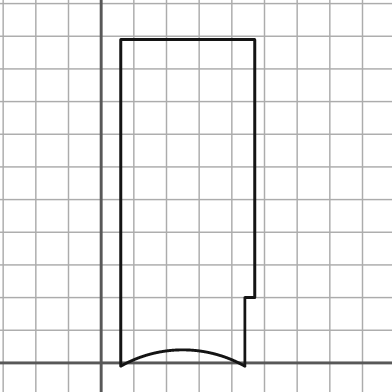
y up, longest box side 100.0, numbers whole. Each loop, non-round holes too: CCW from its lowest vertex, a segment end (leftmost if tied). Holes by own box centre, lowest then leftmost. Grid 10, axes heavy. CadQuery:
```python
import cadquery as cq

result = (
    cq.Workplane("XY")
    .moveTo(6.0, -1.0)
    .threePointArc((25.0, 4.0), (44.0, -1.0))
    .lineTo(44.0, 20.0)
    .lineTo(47.0, 20.0)
    .lineTo(47.0, 99.0)
    .lineTo(6.0, 99.0)
    .close()
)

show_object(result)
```